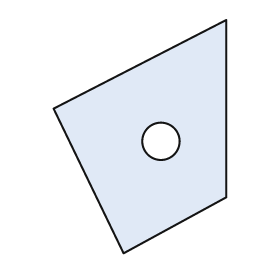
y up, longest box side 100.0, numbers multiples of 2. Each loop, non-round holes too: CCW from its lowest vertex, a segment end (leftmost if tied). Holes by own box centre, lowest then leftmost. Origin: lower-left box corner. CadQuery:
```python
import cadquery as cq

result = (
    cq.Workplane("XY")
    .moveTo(30.0, 0.0)
    .lineTo(74.0, 24.0)
    .lineTo(74.0, 100.0)
    .lineTo(0.0, 62.0)
    .close()
    .moveTo(46.0, 48.0)
    .circle(8.0)
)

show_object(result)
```